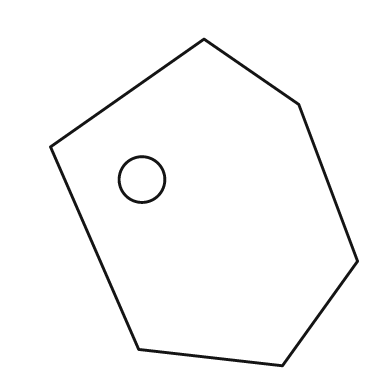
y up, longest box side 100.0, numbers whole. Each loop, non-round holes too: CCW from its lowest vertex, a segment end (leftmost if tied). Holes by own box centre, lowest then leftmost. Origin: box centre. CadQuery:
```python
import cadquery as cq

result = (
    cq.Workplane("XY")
    .moveTo(24.0, -50.0)
    .lineTo(47.0, -18.0)
    .lineTo(29.0, 30.0)
    .lineTo(0.0, 50.0)
    .lineTo(-47.0, 17.0)
    .lineTo(-20.0, -45.0)
    .close()
    .moveTo(-19.0, 7.0)
    .circle(7.0)
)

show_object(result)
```